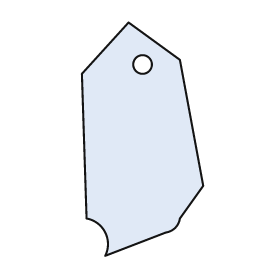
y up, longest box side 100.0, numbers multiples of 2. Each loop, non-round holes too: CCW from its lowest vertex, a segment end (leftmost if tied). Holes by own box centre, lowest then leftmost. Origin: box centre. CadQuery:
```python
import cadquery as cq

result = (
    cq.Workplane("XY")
    .moveTo(-16.0, -50.0)
    .lineTo(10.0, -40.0)
    .threePointArc((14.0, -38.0), (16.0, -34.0))
    .lineTo(26.0, -20.0)
    .lineTo(16.0, 34.0)
    .lineTo(-6.0, 50.0)
    .lineTo(-26.0, 28.0)
    .lineTo(-24.0, -34.0)
    .threePointArc((-16.0, -40.0), (-16.0, -50.0))
    .close()
    .moveTo(0.0, 32.0)
    .circle(4.0)
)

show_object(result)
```